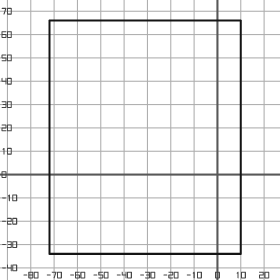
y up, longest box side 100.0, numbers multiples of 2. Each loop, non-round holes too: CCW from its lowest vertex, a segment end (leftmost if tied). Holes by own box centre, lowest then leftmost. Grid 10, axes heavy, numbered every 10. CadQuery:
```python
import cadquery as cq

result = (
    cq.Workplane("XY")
    .moveTo(-72.0, -34.0)
    .lineTo(10.0, -34.0)
    .lineTo(10.0, 66.0)
    .lineTo(-72.0, 66.0)
    .close()
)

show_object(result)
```